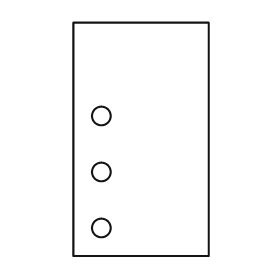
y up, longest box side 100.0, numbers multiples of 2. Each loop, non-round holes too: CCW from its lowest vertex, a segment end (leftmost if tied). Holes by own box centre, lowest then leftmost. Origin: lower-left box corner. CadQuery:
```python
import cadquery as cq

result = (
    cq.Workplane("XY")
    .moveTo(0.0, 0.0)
    .lineTo(58.0, 0.0)
    .lineTo(58.0, 100.0)
    .lineTo(0.0, 100.0)
    .close()
    .moveTo(12.0, 12.0)
    .circle(4.0)
    .moveTo(12.0, 36.0)
    .circle(4.0)
    .moveTo(12.0, 60.0)
    .circle(4.0)
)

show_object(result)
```